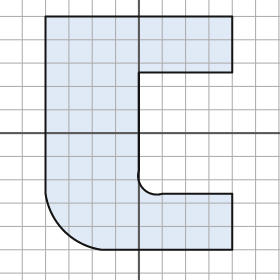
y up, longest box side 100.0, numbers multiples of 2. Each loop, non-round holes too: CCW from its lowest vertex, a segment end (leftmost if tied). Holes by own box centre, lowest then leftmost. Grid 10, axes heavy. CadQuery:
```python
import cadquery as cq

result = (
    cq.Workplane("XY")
    .moveTo(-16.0, -50.0)
    .lineTo(40.0, -50.0)
    .lineTo(40.0, -26.0)
    .lineTo(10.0, -26.0)
    .threePointArc((2.0, -24.0), (0.0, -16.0))
    .lineTo(0.0, 26.0)
    .lineTo(40.0, 26.0)
    .lineTo(40.0, 50.0)
    .lineTo(-40.0, 50.0)
    .lineTo(-40.0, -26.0)
    .threePointArc((-32.0, -42.0), (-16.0, -50.0))
    .close()
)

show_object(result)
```